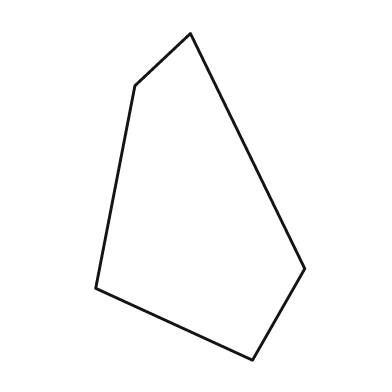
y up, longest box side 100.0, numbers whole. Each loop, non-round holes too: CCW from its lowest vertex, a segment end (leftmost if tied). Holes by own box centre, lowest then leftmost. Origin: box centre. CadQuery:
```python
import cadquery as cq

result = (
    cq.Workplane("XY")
    .moveTo(16.0, -50.0)
    .lineTo(32.0, -22.0)
    .lineTo(-3.0, 50.0)
    .lineTo(-20.0, 34.0)
    .lineTo(-32.0, -28.0)
    .close()
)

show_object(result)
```